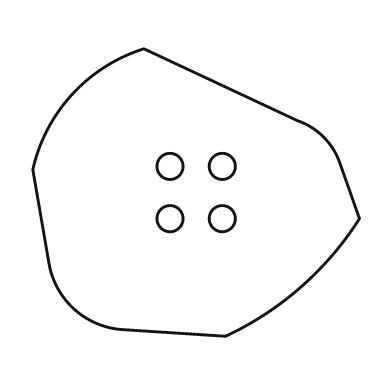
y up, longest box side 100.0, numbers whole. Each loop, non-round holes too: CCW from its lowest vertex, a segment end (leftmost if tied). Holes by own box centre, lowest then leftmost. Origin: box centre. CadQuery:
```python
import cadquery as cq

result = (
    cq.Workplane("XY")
    .moveTo(9.0, -44.0)
    .threePointArc((32.0, -29.0), (50.0, -8.0))
    .lineTo(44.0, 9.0)
    .threePointArc((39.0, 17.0), (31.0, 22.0))
    .lineTo(-16.0, 44.0)
    .threePointArc((-38.0, 30.0), (-50.0, 7.0))
    .lineTo(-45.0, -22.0)
    .threePointArc((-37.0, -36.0), (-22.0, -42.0))
    .close()
    .moveTo(-8.0, -8.0)
    .circle(4.0)
    .moveTo(8.0, -8.0)
    .circle(4.0)
    .moveTo(-8.0, 8.0)
    .circle(4.0)
    .moveTo(8.0, 8.0)
    .circle(4.0)
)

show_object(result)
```